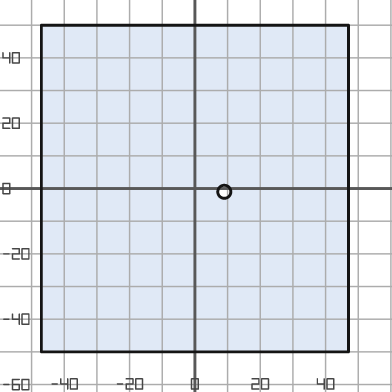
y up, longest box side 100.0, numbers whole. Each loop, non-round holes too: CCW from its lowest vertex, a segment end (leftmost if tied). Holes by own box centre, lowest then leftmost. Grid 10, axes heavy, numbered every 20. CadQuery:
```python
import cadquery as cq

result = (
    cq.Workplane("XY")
    .moveTo(-47.0, -50.0)
    .lineTo(47.0, -50.0)
    .lineTo(47.0, 50.0)
    .lineTo(-47.0, 50.0)
    .close()
    .moveTo(9.0, -1.0)
    .circle(2.0)
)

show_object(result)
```